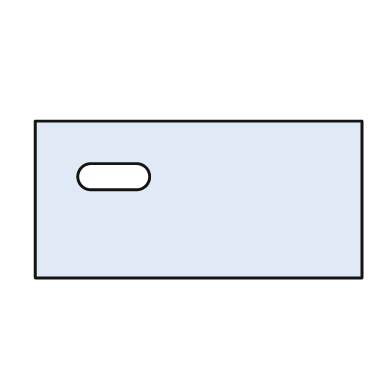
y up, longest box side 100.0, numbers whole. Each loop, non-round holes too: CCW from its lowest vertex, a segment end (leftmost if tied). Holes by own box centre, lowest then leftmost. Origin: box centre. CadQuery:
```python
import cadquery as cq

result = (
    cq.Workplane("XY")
    .moveTo(-50.0, -24.0)
    .lineTo(50.0, -24.0)
    .lineTo(50.0, 24.0)
    .lineTo(-50.0, 24.0)
    .close()
    .moveTo(-33.0, 3.0)
    .lineTo(-19.0, 3.0)
    .threePointArc((-15.0, 7.0), (-19.0, 11.0))
    .lineTo(-33.0, 11.0)
    .threePointArc((-37.0, 7.0), (-33.0, 3.0))
    .close()
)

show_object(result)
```